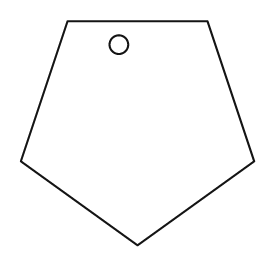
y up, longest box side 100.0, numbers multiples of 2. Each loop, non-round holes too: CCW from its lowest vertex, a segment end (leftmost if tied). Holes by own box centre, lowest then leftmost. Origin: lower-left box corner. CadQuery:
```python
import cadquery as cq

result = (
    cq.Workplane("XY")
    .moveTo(50.0, 0.0)
    .lineTo(100.0, 36.0)
    .lineTo(80.0, 96.0)
    .lineTo(20.0, 96.0)
    .lineTo(0.0, 36.0)
    .close()
    .moveTo(42.0, 86.0)
    .circle(4.0)
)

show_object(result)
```